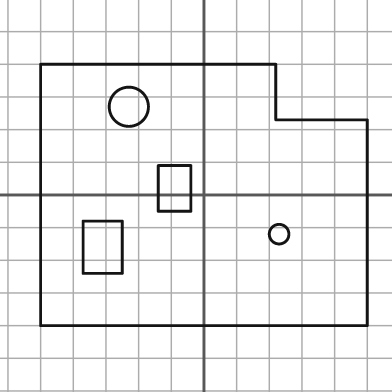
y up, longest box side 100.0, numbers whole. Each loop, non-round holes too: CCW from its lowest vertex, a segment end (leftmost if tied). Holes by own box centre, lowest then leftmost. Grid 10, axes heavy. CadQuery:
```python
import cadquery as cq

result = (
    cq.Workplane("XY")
    .moveTo(-50.0, -40.0)
    .lineTo(50.0, -40.0)
    .lineTo(50.0, 23.0)
    .lineTo(22.0, 23.0)
    .lineTo(22.0, 40.0)
    .lineTo(-50.0, 40.0)
    .close()
    .moveTo(-37.0, -24.0)
    .lineTo(-25.0, -24.0)
    .lineTo(-25.0, -8.0)
    .lineTo(-37.0, -8.0)
    .close()
    .moveTo(23.0, -12.0)
    .circle(3.0)
    .moveTo(-14.0, -5.0)
    .lineTo(-4.0, -5.0)
    .lineTo(-4.0, 9.0)
    .lineTo(-14.0, 9.0)
    .close()
    .moveTo(-23.0, 27.0)
    .circle(6.0)
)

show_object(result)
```